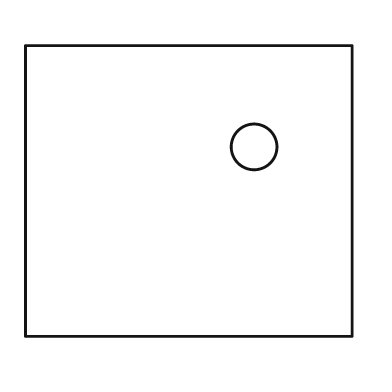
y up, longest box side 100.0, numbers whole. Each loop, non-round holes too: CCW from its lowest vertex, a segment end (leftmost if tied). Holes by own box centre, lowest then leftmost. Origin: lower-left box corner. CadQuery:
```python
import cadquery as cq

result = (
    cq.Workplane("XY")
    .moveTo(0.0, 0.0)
    .lineTo(100.0, 0.0)
    .lineTo(100.0, 89.0)
    .lineTo(0.0, 89.0)
    .close()
    .moveTo(70.0, 58.0)
    .circle(7.0)
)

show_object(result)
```